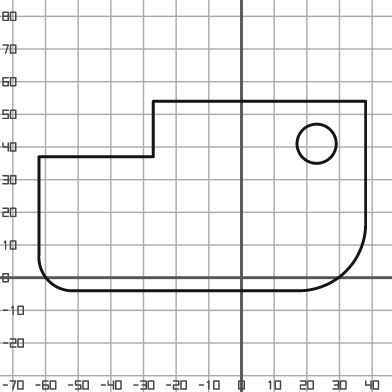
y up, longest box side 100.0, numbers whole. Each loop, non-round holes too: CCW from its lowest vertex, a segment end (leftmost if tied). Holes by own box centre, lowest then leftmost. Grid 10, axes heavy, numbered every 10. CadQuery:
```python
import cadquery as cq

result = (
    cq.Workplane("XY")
    .moveTo(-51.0, -4.0)
    .lineTo(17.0, -4.0)
    .threePointArc((32.0, 2.0), (38.0, 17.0))
    .lineTo(38.0, 54.0)
    .lineTo(-27.0, 54.0)
    .lineTo(-27.0, 37.0)
    .lineTo(-62.0, 37.0)
    .lineTo(-62.0, 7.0)
    .threePointArc((-59.0, -1.0), (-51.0, -4.0))
    .close()
    .moveTo(23.0, 41.0)
    .circle(6.0)
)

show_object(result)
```